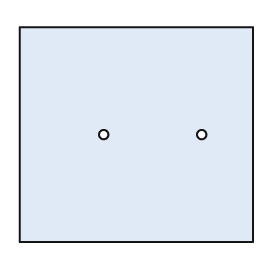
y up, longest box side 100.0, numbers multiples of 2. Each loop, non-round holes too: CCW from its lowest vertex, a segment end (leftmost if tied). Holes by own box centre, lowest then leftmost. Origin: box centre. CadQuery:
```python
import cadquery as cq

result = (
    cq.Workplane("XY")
    .moveTo(-50.0, -46.0)
    .lineTo(50.0, -46.0)
    .lineTo(50.0, 46.0)
    .lineTo(-50.0, 46.0)
    .close()
    .moveTo(-14.0, 0.0)
    .circle(2.0)
    .moveTo(28.0, 0.0)
    .circle(2.0)
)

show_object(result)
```